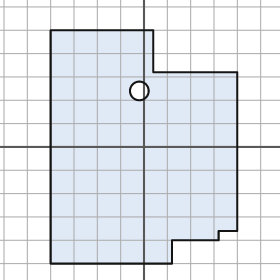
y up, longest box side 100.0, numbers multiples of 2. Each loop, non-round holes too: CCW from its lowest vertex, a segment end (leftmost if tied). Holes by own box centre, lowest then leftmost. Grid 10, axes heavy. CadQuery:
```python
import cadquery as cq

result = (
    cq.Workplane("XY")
    .moveTo(-40.0, -50.0)
    .lineTo(12.0, -50.0)
    .lineTo(12.0, -40.0)
    .lineTo(32.0, -40.0)
    .lineTo(32.0, -36.0)
    .lineTo(40.0, -36.0)
    .lineTo(40.0, 32.0)
    .lineTo(4.0, 32.0)
    .lineTo(4.0, 50.0)
    .lineTo(-40.0, 50.0)
    .close()
    .moveTo(-2.0, 24.0)
    .circle(4.0)
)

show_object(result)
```